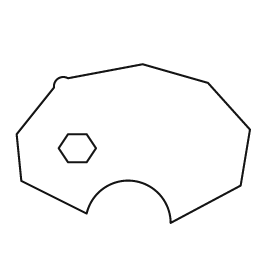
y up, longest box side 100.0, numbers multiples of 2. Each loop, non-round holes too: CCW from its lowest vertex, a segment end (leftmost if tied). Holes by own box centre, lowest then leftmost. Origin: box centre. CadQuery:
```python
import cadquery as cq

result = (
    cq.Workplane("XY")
    .moveTo(16.0, -34.0)
    .lineTo(46.0, -18.0)
    .lineTo(50.0, 6.0)
    .lineTo(32.0, 26.0)
    .lineTo(4.0, 34.0)
    .lineTo(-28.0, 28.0)
    .threePointArc((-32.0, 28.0), (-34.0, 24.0))
    .lineTo(-50.0, 4.0)
    .lineTo(-48.0, -16.0)
    .lineTo(-20.0, -30.0)
    .threePointArc((0.0, -16.0), (16.0, -34.0))
    .close()
    .moveTo(-28.0, -8.0)
    .lineTo(-20.0, -8.0)
    .lineTo(-16.0, -2.0)
    .lineTo(-20.0, 4.0)
    .lineTo(-28.0, 4.0)
    .lineTo(-32.0, -2.0)
    .close()
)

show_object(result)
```